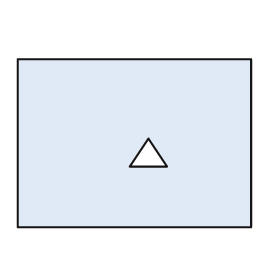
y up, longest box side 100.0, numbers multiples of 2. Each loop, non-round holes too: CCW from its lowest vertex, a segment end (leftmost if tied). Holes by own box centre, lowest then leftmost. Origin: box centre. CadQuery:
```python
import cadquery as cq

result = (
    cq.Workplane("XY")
    .moveTo(-50.0, -36.0)
    .lineTo(50.0, -36.0)
    .lineTo(50.0, 36.0)
    .lineTo(-50.0, 36.0)
    .close()
    .moveTo(-2.0, -10.0)
    .lineTo(14.0, -10.0)
    .lineTo(6.0, 2.0)
    .close()
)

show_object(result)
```